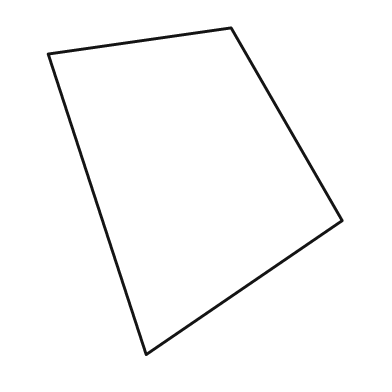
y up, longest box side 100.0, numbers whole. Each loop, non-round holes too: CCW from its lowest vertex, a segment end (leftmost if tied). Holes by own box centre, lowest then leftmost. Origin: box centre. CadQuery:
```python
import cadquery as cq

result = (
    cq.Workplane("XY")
    .moveTo(-15.0, -50.0)
    .lineTo(45.0, -9.0)
    .lineTo(11.0, 50.0)
    .lineTo(-45.0, 42.0)
    .close()
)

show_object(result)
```